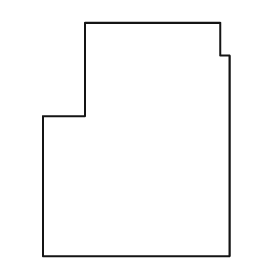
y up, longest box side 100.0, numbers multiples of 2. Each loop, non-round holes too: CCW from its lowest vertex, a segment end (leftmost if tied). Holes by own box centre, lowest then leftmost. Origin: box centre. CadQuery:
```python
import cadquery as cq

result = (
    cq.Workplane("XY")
    .moveTo(-40.0, -50.0)
    .lineTo(40.0, -50.0)
    .lineTo(40.0, 36.0)
    .lineTo(36.0, 36.0)
    .lineTo(36.0, 50.0)
    .lineTo(-22.0, 50.0)
    .lineTo(-22.0, 10.0)
    .lineTo(-40.0, 10.0)
    .close()
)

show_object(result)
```